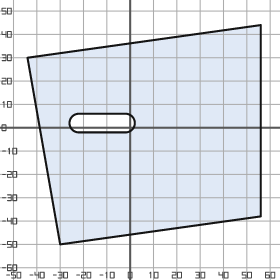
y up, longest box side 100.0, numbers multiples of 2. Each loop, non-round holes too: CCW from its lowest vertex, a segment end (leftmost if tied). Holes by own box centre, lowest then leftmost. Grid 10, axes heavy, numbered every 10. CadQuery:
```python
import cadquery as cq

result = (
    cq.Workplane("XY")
    .moveTo(-30.0, -50.0)
    .lineTo(56.0, -38.0)
    .lineTo(56.0, 44.0)
    .lineTo(-44.0, 30.0)
    .close()
    .moveTo(-22.0, -2.0)
    .lineTo(-2.0, -2.0)
    .threePointArc((2.0, 2.0), (-2.0, 6.0))
    .lineTo(-22.0, 6.0)
    .threePointArc((-26.0, 2.0), (-22.0, -2.0))
    .close()
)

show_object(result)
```